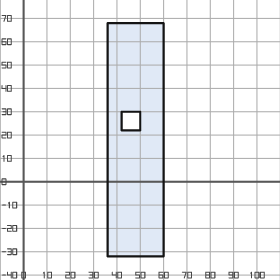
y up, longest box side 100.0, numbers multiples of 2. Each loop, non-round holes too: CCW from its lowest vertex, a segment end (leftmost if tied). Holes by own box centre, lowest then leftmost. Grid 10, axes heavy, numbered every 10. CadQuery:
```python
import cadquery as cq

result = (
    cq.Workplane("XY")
    .moveTo(36.0, -32.0)
    .lineTo(60.0, -32.0)
    .lineTo(60.0, 68.0)
    .lineTo(36.0, 68.0)
    .close()
    .moveTo(42.0, 22.0)
    .lineTo(50.0, 22.0)
    .lineTo(50.0, 30.0)
    .lineTo(42.0, 30.0)
    .close()
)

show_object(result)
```